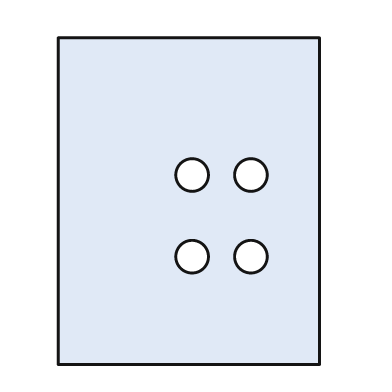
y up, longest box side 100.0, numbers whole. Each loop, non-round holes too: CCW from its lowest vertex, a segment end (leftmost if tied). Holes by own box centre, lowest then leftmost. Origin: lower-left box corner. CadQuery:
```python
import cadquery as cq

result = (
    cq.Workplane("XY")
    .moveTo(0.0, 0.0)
    .lineTo(80.0, 0.0)
    .lineTo(80.0, 100.0)
    .lineTo(0.0, 100.0)
    .close()
    .moveTo(41.0, 33.0)
    .circle(5.0)
    .moveTo(59.0, 33.0)
    .circle(5.0)
    .moveTo(41.0, 58.0)
    .circle(5.0)
    .moveTo(59.0, 58.0)
    .circle(5.0)
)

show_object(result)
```